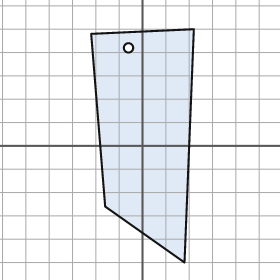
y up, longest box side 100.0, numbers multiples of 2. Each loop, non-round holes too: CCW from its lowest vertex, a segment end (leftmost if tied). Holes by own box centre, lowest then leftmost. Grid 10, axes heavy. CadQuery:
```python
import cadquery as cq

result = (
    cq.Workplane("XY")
    .moveTo(18.0, -50.0)
    .lineTo(22.0, 50.0)
    .lineTo(-22.0, 48.0)
    .lineTo(-16.0, -26.0)
    .close()
    .moveTo(-6.0, 42.0)
    .circle(2.0)
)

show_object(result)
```